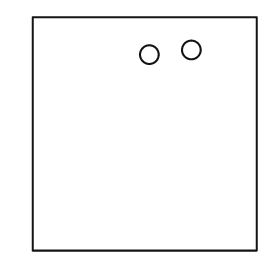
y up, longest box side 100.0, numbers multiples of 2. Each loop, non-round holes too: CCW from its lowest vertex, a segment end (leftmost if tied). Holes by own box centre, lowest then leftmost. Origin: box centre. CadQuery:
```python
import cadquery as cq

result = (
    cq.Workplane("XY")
    .moveTo(-48.0, -50.0)
    .lineTo(48.0, -50.0)
    .lineTo(48.0, 50.0)
    .lineTo(-48.0, 50.0)
    .close()
    .moveTo(2.0, 34.0)
    .circle(4.0)
    .moveTo(20.0, 36.0)
    .circle(4.0)
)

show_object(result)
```